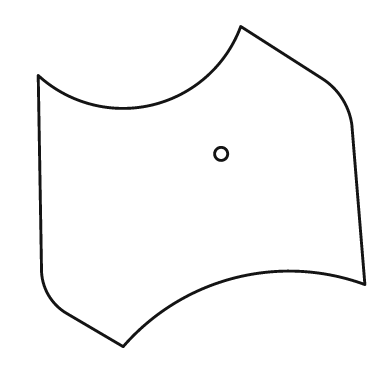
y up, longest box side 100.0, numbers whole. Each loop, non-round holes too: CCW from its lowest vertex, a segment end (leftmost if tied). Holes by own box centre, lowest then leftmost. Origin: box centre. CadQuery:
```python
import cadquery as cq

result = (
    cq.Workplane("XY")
    .moveTo(-24.0, -49.0)
    .threePointArc((10.0, -28.0), (50.0, -30.0))
    .lineTo(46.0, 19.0)
    .threePointArc((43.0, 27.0), (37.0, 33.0))
    .lineTo(12.0, 49.0)
    .threePointArc((-15.0, 25.0), (-50.0, 34.0))
    .lineTo(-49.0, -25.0)
    .threePointArc((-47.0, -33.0), (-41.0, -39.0))
    .close()
    .moveTo(6.0, 10.0)
    .circle(2.0)
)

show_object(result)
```